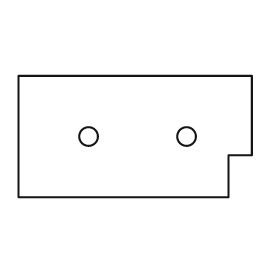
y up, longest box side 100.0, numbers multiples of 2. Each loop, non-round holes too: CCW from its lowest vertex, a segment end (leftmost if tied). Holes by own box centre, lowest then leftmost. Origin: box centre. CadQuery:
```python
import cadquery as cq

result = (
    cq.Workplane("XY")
    .moveTo(-50.0, -26.0)
    .lineTo(40.0, -26.0)
    .lineTo(40.0, -8.0)
    .lineTo(50.0, -8.0)
    .lineTo(50.0, 26.0)
    .lineTo(-50.0, 26.0)
    .close()
    .moveTo(-20.0, 0.0)
    .circle(4.0)
    .moveTo(22.0, 0.0)
    .circle(4.0)
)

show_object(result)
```